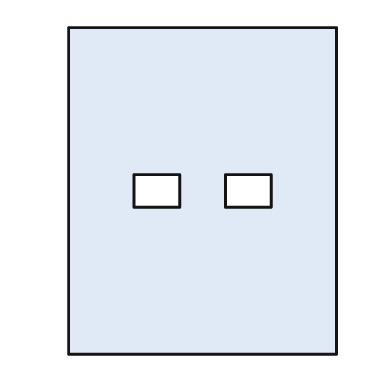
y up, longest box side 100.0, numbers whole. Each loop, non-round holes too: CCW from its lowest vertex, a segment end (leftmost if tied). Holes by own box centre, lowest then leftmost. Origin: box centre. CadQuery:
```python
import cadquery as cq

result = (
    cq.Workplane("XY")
    .moveTo(-41.0, -50.0)
    .lineTo(41.0, -50.0)
    .lineTo(41.0, 50.0)
    .lineTo(-41.0, 50.0)
    .close()
    .moveTo(-21.0, -5.0)
    .lineTo(-7.0, -5.0)
    .lineTo(-7.0, 5.0)
    .lineTo(-21.0, 5.0)
    .close()
    .moveTo(7.0, -5.0)
    .lineTo(21.0, -5.0)
    .lineTo(21.0, 5.0)
    .lineTo(7.0, 5.0)
    .close()
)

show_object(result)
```